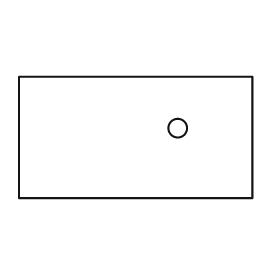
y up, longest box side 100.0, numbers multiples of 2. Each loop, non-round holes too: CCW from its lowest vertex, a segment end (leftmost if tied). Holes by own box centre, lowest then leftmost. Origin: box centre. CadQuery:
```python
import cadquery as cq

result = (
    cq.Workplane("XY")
    .moveTo(-50.0, -26.0)
    .lineTo(50.0, -26.0)
    .lineTo(50.0, 26.0)
    .lineTo(-50.0, 26.0)
    .close()
    .moveTo(18.0, 4.0)
    .circle(4.0)
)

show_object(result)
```